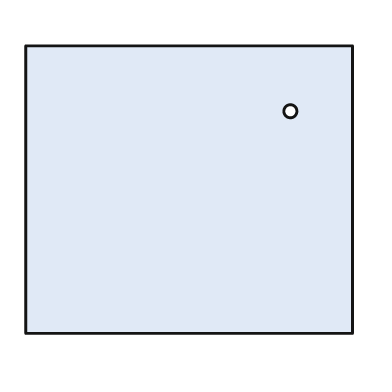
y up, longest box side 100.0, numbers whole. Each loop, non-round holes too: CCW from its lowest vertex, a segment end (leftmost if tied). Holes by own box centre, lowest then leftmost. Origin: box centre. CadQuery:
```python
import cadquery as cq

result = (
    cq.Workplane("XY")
    .moveTo(-50.0, -44.0)
    .lineTo(50.0, -44.0)
    .lineTo(50.0, 44.0)
    .lineTo(-50.0, 44.0)
    .close()
    .moveTo(31.0, 24.0)
    .circle(2.0)
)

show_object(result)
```